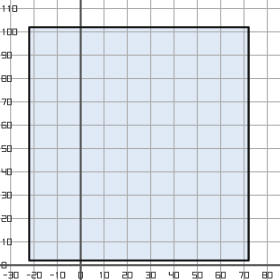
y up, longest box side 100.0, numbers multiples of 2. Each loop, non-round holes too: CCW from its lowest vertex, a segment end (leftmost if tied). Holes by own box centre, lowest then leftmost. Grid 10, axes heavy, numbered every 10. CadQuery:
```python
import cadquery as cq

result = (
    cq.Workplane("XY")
    .moveTo(-22.0, 2.0)
    .lineTo(72.0, 2.0)
    .lineTo(72.0, 102.0)
    .lineTo(-22.0, 102.0)
    .close()
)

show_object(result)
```